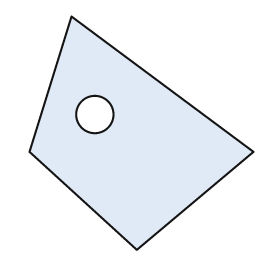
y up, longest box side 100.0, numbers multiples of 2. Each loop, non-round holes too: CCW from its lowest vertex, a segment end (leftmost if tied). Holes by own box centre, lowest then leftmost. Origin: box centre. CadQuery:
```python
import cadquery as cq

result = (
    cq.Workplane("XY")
    .moveTo(-2.0, -50.0)
    .lineTo(48.0, -8.0)
    .lineTo(-30.0, 50.0)
    .lineTo(-48.0, -8.0)
    .close()
    .moveTo(-20.0, 8.0)
    .circle(8.0)
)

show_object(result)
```